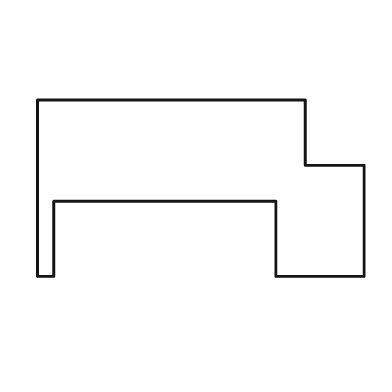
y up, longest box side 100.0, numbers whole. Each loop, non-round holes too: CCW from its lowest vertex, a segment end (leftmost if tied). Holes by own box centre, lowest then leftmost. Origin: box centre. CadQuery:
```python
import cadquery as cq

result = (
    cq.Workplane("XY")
    .moveTo(-50.0, -27.0)
    .lineTo(-45.0, -27.0)
    .lineTo(-45.0, -4.0)
    .lineTo(23.0, -4.0)
    .lineTo(23.0, -27.0)
    .lineTo(50.0, -27.0)
    .lineTo(50.0, 7.0)
    .lineTo(32.0, 7.0)
    .lineTo(32.0, 27.0)
    .lineTo(-50.0, 27.0)
    .close()
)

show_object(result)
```